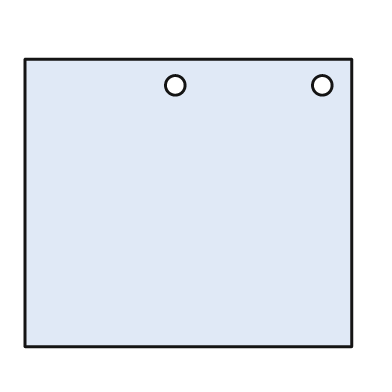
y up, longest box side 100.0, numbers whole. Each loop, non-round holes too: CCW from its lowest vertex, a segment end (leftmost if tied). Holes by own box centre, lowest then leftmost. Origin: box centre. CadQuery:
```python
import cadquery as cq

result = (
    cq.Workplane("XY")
    .moveTo(-50.0, -44.0)
    .lineTo(50.0, -44.0)
    .lineTo(50.0, 44.0)
    .lineTo(-50.0, 44.0)
    .close()
    .moveTo(-4.0, 36.0)
    .circle(3.0)
    .moveTo(41.0, 36.0)
    .circle(3.0)
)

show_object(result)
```